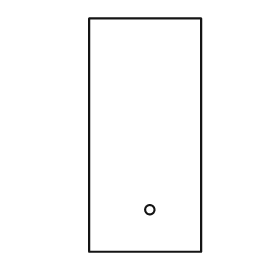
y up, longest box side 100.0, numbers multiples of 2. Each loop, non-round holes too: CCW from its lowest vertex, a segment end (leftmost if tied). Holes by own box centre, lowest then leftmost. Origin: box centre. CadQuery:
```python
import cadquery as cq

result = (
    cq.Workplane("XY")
    .moveTo(-24.0, -50.0)
    .lineTo(24.0, -50.0)
    .lineTo(24.0, 50.0)
    .lineTo(-24.0, 50.0)
    .close()
    .moveTo(2.0, -32.0)
    .circle(2.0)
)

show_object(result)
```